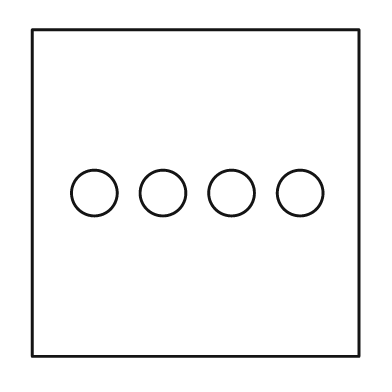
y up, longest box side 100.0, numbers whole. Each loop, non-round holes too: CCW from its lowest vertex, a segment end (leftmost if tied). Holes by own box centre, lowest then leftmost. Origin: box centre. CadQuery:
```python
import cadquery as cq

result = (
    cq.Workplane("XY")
    .moveTo(-50.0, -50.0)
    .lineTo(50.0, -50.0)
    .lineTo(50.0, 50.0)
    .lineTo(-50.0, 50.0)
    .close()
    .moveTo(-31.0, 0.0)
    .circle(7.0)
    .moveTo(-10.0, 0.0)
    .circle(7.0)
    .moveTo(11.0, 0.0)
    .circle(7.0)
    .moveTo(32.0, 0.0)
    .circle(7.0)
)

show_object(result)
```